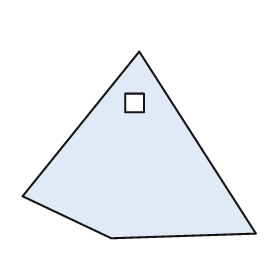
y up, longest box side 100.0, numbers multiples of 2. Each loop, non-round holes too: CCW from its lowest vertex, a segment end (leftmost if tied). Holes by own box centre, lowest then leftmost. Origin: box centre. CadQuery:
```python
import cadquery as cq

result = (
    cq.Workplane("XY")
    .moveTo(-12.0, -40.0)
    .lineTo(50.0, -38.0)
    .lineTo(0.0, 40.0)
    .lineTo(-50.0, -22.0)
    .close()
    .moveTo(-6.0, 14.0)
    .lineTo(2.0, 14.0)
    .lineTo(2.0, 22.0)
    .lineTo(-6.0, 22.0)
    .close()
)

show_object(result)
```